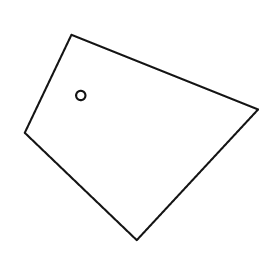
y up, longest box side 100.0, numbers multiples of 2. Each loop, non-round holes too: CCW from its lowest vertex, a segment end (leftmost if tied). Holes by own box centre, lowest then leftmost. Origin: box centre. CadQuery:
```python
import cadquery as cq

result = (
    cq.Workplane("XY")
    .moveTo(-2.0, -44.0)
    .lineTo(50.0, 12.0)
    .lineTo(-30.0, 44.0)
    .lineTo(-50.0, 2.0)
    .close()
    .moveTo(-26.0, 18.0)
    .circle(2.0)
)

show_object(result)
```